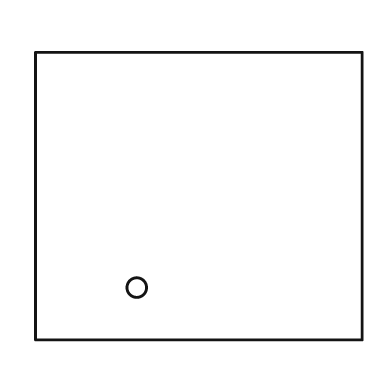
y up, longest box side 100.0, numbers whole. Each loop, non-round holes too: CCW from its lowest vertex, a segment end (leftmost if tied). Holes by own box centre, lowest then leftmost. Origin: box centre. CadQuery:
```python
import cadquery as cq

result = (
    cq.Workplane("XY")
    .moveTo(-50.0, -44.0)
    .lineTo(50.0, -44.0)
    .lineTo(50.0, 44.0)
    .lineTo(-50.0, 44.0)
    .close()
    .moveTo(-19.0, -28.0)
    .circle(3.0)
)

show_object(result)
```